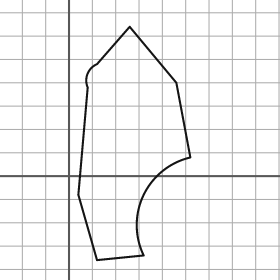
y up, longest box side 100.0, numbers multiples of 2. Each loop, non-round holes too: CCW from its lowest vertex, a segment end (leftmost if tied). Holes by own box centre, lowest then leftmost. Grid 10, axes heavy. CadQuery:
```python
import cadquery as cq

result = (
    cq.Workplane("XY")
    .moveTo(12.0, -36.0)
    .lineTo(32.0, -34.0)
    .threePointArc((32.0, -8.0), (52.0, 8.0))
    .lineTo(46.0, 40.0)
    .lineTo(26.0, 64.0)
    .lineTo(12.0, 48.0)
    .threePointArc((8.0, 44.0), (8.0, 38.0))
    .lineTo(4.0, -8.0)
    .close()
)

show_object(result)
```